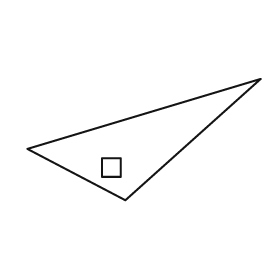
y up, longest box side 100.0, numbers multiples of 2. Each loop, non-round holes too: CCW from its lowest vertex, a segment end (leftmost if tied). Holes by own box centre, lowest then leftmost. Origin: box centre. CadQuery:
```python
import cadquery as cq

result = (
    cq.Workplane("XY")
    .moveTo(-8.0, -26.0)
    .lineTo(50.0, 26.0)
    .lineTo(-50.0, -4.0)
    .close()
    .moveTo(-18.0, -16.0)
    .lineTo(-10.0, -16.0)
    .lineTo(-10.0, -8.0)
    .lineTo(-18.0, -8.0)
    .close()
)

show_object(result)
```